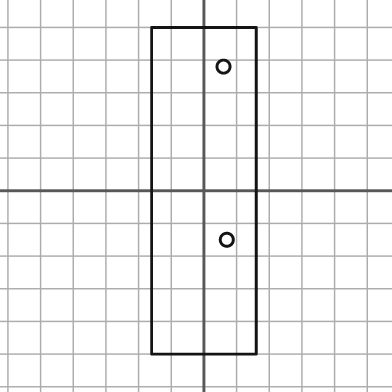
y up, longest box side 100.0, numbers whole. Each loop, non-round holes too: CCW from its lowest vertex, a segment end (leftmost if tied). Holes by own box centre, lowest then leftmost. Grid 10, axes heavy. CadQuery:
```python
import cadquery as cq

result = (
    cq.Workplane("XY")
    .moveTo(-16.0, -50.0)
    .lineTo(16.0, -50.0)
    .lineTo(16.0, 50.0)
    .lineTo(-16.0, 50.0)
    .close()
    .moveTo(7.0, -15.0)
    .circle(2.0)
    .moveTo(6.0, 38.0)
    .circle(2.0)
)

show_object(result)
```